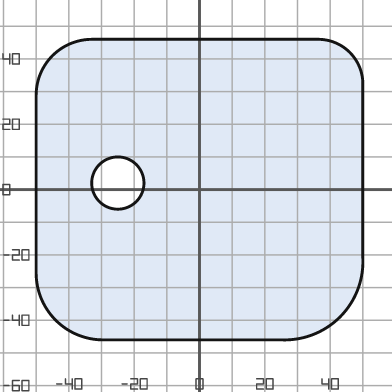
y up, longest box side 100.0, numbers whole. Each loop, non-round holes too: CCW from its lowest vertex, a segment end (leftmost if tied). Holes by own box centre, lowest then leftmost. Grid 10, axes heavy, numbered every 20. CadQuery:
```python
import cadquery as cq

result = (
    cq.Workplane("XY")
    .moveTo(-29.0, -46.0)
    .lineTo(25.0, -46.0)
    .threePointArc((43.0, -39.0), (50.0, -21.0))
    .lineTo(50.0, 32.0)
    .threePointArc((46.0, 42.0), (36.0, 46.0))
    .lineTo(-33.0, 46.0)
    .threePointArc((-45.0, 41.0), (-50.0, 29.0))
    .lineTo(-50.0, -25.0)
    .threePointArc((-44.0, -40.0), (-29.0, -46.0))
    .close()
    .moveTo(-25.0, 2.0)
    .circle(8.0)
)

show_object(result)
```